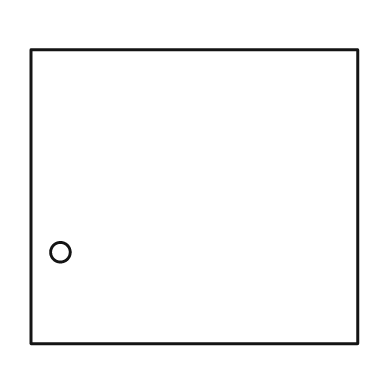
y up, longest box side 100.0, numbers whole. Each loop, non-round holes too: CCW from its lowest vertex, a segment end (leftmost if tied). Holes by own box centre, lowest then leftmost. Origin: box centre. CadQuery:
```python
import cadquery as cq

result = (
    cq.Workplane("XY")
    .moveTo(-50.0, -45.0)
    .lineTo(50.0, -45.0)
    .lineTo(50.0, 45.0)
    .lineTo(-50.0, 45.0)
    .close()
    .moveTo(-41.0, -17.0)
    .circle(3.0)
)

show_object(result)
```